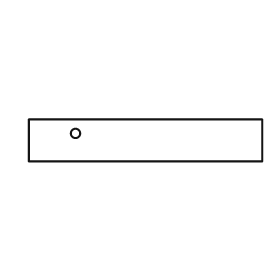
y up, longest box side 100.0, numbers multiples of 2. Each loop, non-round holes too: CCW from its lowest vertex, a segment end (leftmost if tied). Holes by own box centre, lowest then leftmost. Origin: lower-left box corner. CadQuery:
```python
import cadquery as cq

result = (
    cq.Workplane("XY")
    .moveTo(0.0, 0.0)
    .lineTo(100.0, 0.0)
    .lineTo(100.0, 18.0)
    .lineTo(0.0, 18.0)
    .close()
    .moveTo(20.0, 12.0)
    .circle(2.0)
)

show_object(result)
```